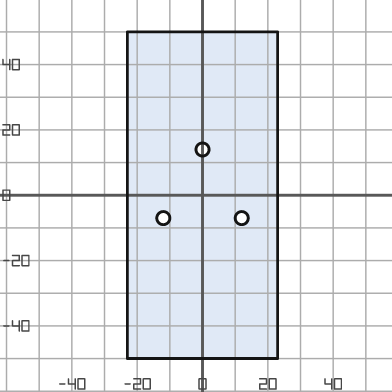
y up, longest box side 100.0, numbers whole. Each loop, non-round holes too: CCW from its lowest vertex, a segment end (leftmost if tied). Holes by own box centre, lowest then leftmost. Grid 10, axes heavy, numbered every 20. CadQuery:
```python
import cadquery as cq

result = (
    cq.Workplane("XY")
    .moveTo(-23.0, -50.0)
    .lineTo(23.0, -50.0)
    .lineTo(23.0, 50.0)
    .lineTo(-23.0, 50.0)
    .close()
    .moveTo(-12.0, -7.0)
    .circle(2.0)
    .moveTo(12.0, -7.0)
    .circle(2.0)
    .moveTo(0.0, 14.0)
    .circle(2.0)
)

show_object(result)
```